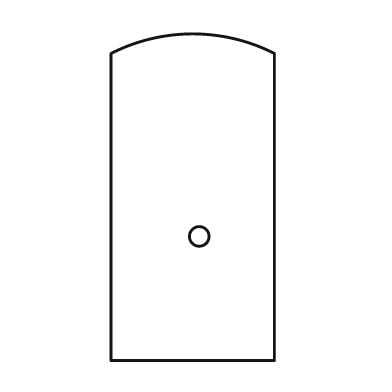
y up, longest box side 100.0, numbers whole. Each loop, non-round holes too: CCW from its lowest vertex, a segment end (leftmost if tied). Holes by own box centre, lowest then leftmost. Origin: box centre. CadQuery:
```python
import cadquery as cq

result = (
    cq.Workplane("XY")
    .moveTo(-25.0, -50.0)
    .lineTo(25.0, -50.0)
    .lineTo(25.0, 44.0)
    .threePointArc((0.0, 50.0), (-25.0, 44.0))
    .close()
    .moveTo(2.0, -12.0)
    .circle(3.0)
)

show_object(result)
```